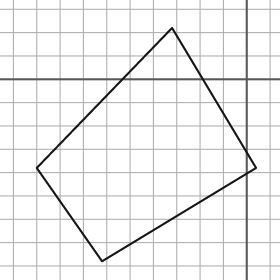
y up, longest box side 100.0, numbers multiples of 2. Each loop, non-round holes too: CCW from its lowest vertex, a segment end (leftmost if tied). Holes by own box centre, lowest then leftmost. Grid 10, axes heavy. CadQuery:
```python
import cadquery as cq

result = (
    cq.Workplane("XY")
    .moveTo(-62.0, -78.0)
    .lineTo(4.0, -38.0)
    .lineTo(-32.0, 22.0)
    .lineTo(-90.0, -38.0)
    .close()
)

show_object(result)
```